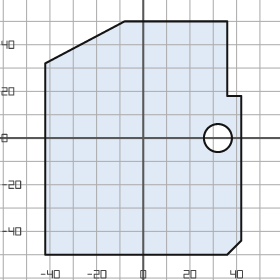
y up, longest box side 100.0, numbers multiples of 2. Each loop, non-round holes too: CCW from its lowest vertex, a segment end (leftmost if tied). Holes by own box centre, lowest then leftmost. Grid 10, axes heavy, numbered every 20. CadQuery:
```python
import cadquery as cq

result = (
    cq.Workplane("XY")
    .moveTo(-42.0, -50.0)
    .lineTo(36.0, -50.0)
    .lineTo(42.0, -44.0)
    .lineTo(42.0, 18.0)
    .lineTo(36.0, 18.0)
    .lineTo(36.0, 50.0)
    .lineTo(-8.0, 50.0)
    .lineTo(-42.0, 32.0)
    .close()
    .moveTo(32.0, 0.0)
    .circle(6.0)
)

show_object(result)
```